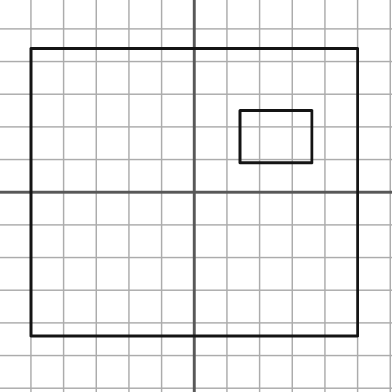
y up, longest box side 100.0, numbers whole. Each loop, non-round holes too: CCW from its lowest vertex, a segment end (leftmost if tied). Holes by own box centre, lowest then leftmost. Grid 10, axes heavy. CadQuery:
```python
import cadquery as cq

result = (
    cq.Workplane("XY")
    .moveTo(-50.0, -44.0)
    .lineTo(50.0, -44.0)
    .lineTo(50.0, 44.0)
    .lineTo(-50.0, 44.0)
    .close()
    .moveTo(14.0, 9.0)
    .lineTo(36.0, 9.0)
    .lineTo(36.0, 25.0)
    .lineTo(14.0, 25.0)
    .close()
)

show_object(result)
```